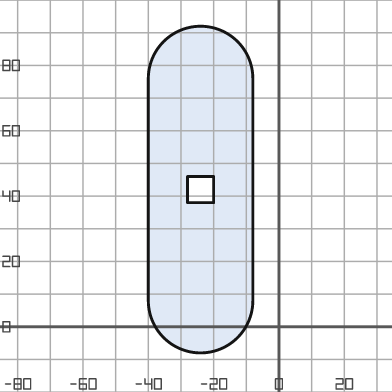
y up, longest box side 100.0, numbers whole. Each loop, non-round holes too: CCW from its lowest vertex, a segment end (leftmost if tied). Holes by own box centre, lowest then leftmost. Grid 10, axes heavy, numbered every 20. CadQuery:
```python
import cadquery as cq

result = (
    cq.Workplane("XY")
    .moveTo(-40.0, 8.0)
    .threePointArc((-24.0, -8.0), (-8.0, 8.0))
    .lineTo(-8.0, 76.0)
    .threePointArc((-24.0, 92.0), (-40.0, 76.0))
    .close()
    .moveTo(-28.0, 38.0)
    .lineTo(-20.0, 38.0)
    .lineTo(-20.0, 46.0)
    .lineTo(-28.0, 46.0)
    .close()
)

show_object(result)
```